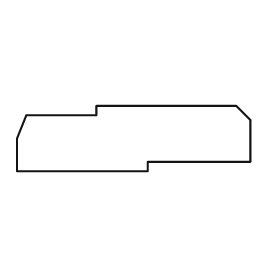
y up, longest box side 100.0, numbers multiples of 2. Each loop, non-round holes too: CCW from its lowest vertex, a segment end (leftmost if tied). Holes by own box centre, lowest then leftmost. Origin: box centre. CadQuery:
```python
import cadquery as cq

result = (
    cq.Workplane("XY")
    .moveTo(-50.0, -14.0)
    .lineTo(6.0, -14.0)
    .lineTo(6.0, -10.0)
    .lineTo(50.0, -10.0)
    .lineTo(50.0, 8.0)
    .lineTo(44.0, 14.0)
    .lineTo(-16.0, 14.0)
    .lineTo(-16.0, 10.0)
    .lineTo(-46.0, 10.0)
    .lineTo(-50.0, 0.0)
    .close()
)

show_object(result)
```